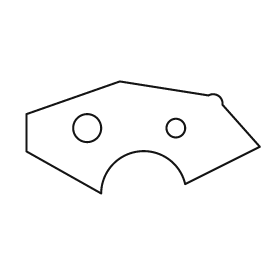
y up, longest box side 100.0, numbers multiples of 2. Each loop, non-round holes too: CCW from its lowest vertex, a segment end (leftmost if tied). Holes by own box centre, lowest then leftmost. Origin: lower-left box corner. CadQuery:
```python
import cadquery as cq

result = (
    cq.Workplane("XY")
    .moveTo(32.0, 0.0)
    .threePointArc((48.0, 18.0), (68.0, 4.0))
    .lineTo(100.0, 20.0)
    .lineTo(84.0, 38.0)
    .threePointArc((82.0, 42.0), (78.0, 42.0))
    .lineTo(40.0, 48.0)
    .lineTo(0.0, 34.0)
    .lineTo(0.0, 18.0)
    .close()
    .moveTo(26.0, 28.0)
    .circle(6.0)
    .moveTo(64.0, 28.0)
    .circle(4.0)
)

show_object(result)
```